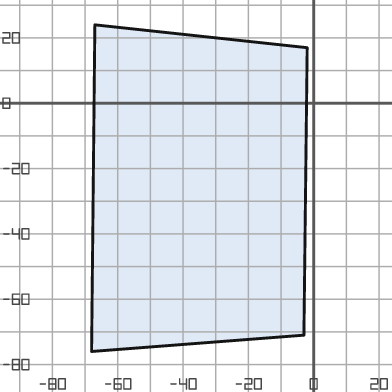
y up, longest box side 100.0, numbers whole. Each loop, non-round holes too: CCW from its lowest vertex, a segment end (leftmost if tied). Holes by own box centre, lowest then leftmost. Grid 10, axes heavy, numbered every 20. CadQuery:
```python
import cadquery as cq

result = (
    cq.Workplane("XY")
    .moveTo(-68.0, -76.0)
    .lineTo(-3.0, -71.0)
    .lineTo(-2.0, 17.0)
    .lineTo(-67.0, 24.0)
    .close()
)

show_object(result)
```